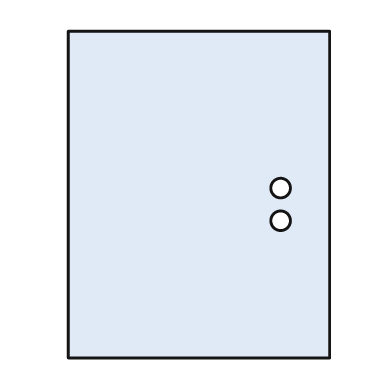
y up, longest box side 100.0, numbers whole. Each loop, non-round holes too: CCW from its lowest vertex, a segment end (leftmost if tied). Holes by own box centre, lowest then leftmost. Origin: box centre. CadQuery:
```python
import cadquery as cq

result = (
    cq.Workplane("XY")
    .moveTo(-40.0, -50.0)
    .lineTo(40.0, -50.0)
    .lineTo(40.0, 50.0)
    .lineTo(-40.0, 50.0)
    .close()
    .moveTo(25.0, -8.0)
    .circle(3.0)
    .moveTo(25.0, 2.0)
    .circle(3.0)
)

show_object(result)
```